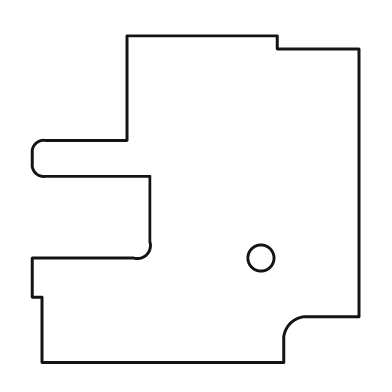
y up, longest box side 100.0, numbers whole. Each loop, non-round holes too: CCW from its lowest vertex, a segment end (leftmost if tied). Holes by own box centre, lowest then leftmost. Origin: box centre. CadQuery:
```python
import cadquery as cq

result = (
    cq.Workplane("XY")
    .moveTo(-47.0, -50.0)
    .lineTo(27.0, -50.0)
    .lineTo(27.0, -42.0)
    .threePointArc((29.0, -38.0), (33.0, -36.0))
    .lineTo(50.0, -36.0)
    .lineTo(50.0, 46.0)
    .lineTo(25.0, 46.0)
    .lineTo(25.0, 50.0)
    .lineTo(-21.0, 50.0)
    .lineTo(-21.0, 18.0)
    .lineTo(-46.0, 18.0)
    .threePointArc((-49.0, 17.0), (-50.0, 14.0))
    .lineTo(-50.0, 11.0)
    .threePointArc((-49.0, 8.0), (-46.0, 7.0))
    .lineTo(-14.0, 7.0)
    .lineTo(-14.0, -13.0)
    .threePointArc((-15.0, -17.0), (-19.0, -18.0))
    .lineTo(-50.0, -18.0)
    .lineTo(-50.0, -30.0)
    .lineTo(-47.0, -30.0)
    .close()
    .moveTo(20.0, -18.0)
    .circle(4.0)
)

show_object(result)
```